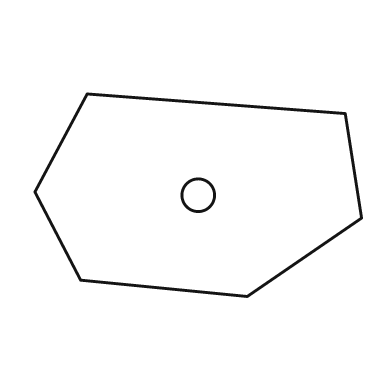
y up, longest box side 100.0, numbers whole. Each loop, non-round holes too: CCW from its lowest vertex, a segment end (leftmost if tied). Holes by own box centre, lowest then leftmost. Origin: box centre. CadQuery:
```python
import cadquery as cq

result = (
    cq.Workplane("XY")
    .moveTo(15.0, -31.0)
    .lineTo(50.0, -7.0)
    .lineTo(45.0, 25.0)
    .lineTo(-34.0, 31.0)
    .lineTo(-50.0, 1.0)
    .lineTo(-36.0, -26.0)
    .close()
    .moveTo(0.0, 0.0)
    .circle(5.0)
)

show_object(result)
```